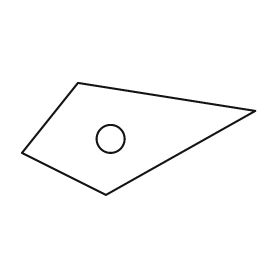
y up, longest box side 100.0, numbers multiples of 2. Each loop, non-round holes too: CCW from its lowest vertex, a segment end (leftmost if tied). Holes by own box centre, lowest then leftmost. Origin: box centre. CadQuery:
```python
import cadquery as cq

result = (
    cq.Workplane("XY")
    .moveTo(-14.0, -24.0)
    .lineTo(50.0, 12.0)
    .lineTo(-26.0, 24.0)
    .lineTo(-50.0, -6.0)
    .close()
    .moveTo(-12.0, 0.0)
    .circle(6.0)
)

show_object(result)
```